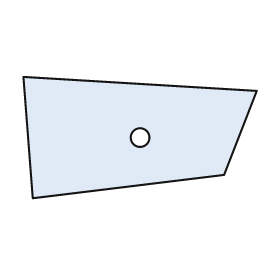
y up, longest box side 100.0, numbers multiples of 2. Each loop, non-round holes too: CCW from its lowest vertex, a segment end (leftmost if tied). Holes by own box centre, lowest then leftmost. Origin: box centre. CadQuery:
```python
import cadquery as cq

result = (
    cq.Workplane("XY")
    .moveTo(-46.0, -26.0)
    .lineTo(36.0, -16.0)
    .lineTo(50.0, 20.0)
    .lineTo(-50.0, 26.0)
    .close()
    .moveTo(0.0, 0.0)
    .circle(4.0)
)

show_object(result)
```